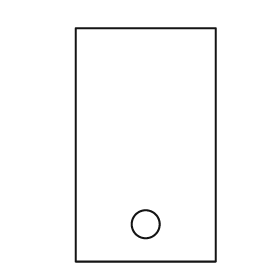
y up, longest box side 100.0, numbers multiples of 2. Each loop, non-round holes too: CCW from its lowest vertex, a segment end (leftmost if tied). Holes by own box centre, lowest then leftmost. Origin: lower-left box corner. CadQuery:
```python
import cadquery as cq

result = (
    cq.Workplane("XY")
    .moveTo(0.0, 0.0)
    .lineTo(60.0, 0.0)
    .lineTo(60.0, 100.0)
    .lineTo(0.0, 100.0)
    .close()
    .moveTo(30.0, 16.0)
    .circle(6.0)
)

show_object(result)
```